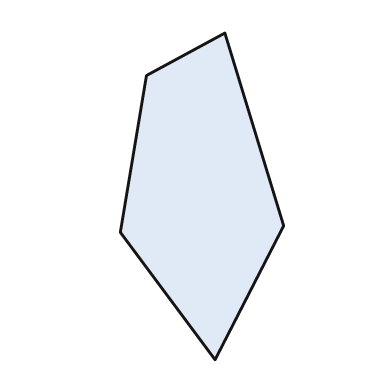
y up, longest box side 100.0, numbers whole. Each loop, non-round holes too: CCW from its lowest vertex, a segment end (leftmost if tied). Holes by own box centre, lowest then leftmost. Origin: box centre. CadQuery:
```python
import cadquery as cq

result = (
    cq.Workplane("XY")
    .moveTo(4.0, -50.0)
    .lineTo(25.0, -9.0)
    .lineTo(7.0, 50.0)
    .lineTo(-17.0, 37.0)
    .lineTo(-25.0, -11.0)
    .close()
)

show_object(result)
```